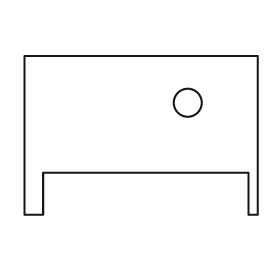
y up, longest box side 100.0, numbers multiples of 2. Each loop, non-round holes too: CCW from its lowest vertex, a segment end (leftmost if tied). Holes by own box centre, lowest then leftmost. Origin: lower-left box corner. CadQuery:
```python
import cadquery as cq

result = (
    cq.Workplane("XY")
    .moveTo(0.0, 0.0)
    .lineTo(8.0, 0.0)
    .lineTo(8.0, 18.0)
    .lineTo(96.0, 18.0)
    .lineTo(96.0, 0.0)
    .lineTo(100.0, 0.0)
    .lineTo(100.0, 68.0)
    .lineTo(0.0, 68.0)
    .close()
    .moveTo(70.0, 48.0)
    .circle(6.0)
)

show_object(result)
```